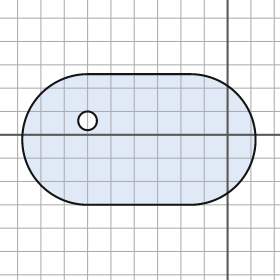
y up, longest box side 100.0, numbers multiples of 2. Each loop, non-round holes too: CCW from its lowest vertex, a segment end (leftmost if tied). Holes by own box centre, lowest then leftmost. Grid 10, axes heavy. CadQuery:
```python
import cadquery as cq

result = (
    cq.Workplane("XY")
    .moveTo(-60.0, -30.0)
    .lineTo(-16.0, -30.0)
    .threePointArc((12.0, -2.0), (-16.0, 26.0))
    .lineTo(-60.0, 26.0)
    .threePointArc((-88.0, -2.0), (-60.0, -30.0))
    .close()
    .moveTo(-60.0, 6.0)
    .circle(4.0)
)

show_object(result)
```